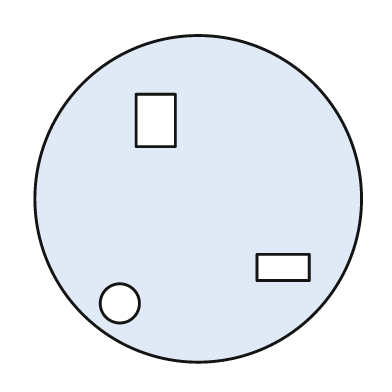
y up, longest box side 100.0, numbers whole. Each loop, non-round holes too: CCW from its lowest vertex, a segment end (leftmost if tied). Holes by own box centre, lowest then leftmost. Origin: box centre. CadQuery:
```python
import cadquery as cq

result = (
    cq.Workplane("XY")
    .moveTo(0.0, 0.0)
    .circle(50.0)
    .moveTo(-24.0, -32.0)
    .circle(6.0)
    .moveTo(18.0, -25.0)
    .lineTo(34.0, -25.0)
    .lineTo(34.0, -17.0)
    .lineTo(18.0, -17.0)
    .close()
    .moveTo(-19.0, 16.0)
    .lineTo(-7.0, 16.0)
    .lineTo(-7.0, 32.0)
    .lineTo(-19.0, 32.0)
    .close()
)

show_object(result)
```